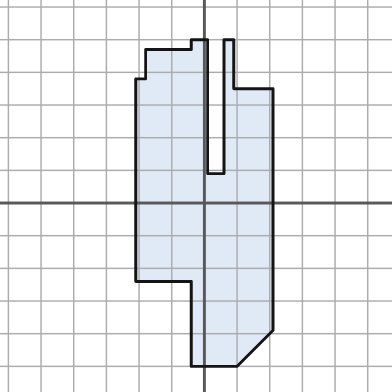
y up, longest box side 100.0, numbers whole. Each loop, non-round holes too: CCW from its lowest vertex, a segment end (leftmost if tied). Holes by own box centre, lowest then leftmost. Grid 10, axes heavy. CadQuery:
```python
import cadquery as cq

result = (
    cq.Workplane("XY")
    .moveTo(-4.0, -50.0)
    .lineTo(10.0, -50.0)
    .lineTo(21.0, -39.0)
    .lineTo(21.0, 35.0)
    .lineTo(9.0, 35.0)
    .lineTo(9.0, 50.0)
    .lineTo(6.0, 50.0)
    .lineTo(6.0, 9.0)
    .lineTo(1.0, 9.0)
    .lineTo(1.0, 50.0)
    .lineTo(-4.0, 50.0)
    .lineTo(-4.0, 47.0)
    .lineTo(-18.0, 47.0)
    .lineTo(-18.0, 38.0)
    .lineTo(-21.0, 38.0)
    .lineTo(-21.0, -24.0)
    .lineTo(-4.0, -24.0)
    .close()
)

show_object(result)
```